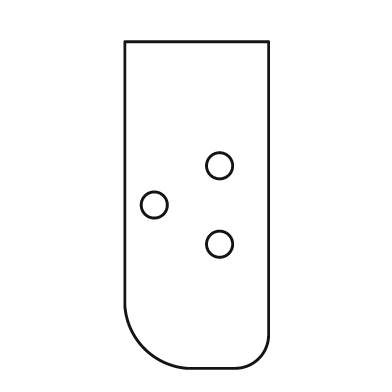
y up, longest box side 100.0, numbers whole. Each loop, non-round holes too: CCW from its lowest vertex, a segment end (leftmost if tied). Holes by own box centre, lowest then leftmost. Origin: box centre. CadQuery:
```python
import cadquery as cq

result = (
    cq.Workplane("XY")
    .moveTo(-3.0, -50.0)
    .lineTo(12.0, -50.0)
    .threePointArc((19.0, -47.0), (22.0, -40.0))
    .lineTo(22.0, 50.0)
    .lineTo(-22.0, 50.0)
    .lineTo(-22.0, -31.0)
    .threePointArc((-16.0, -44.0), (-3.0, -50.0))
    .close()
    .moveTo(7.0, -12.0)
    .circle(4.0)
    .moveTo(-13.0, 0.0)
    .circle(4.0)
    .moveTo(7.0, 12.0)
    .circle(4.0)
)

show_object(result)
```